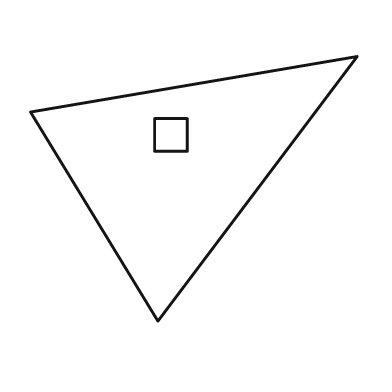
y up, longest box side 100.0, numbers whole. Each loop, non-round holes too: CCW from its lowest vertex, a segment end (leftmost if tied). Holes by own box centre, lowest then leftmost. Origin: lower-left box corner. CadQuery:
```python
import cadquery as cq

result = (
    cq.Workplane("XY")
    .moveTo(39.0, 0.0)
    .lineTo(100.0, 81.0)
    .lineTo(0.0, 64.0)
    .close()
    .moveTo(38.0, 52.0)
    .lineTo(48.0, 52.0)
    .lineTo(48.0, 62.0)
    .lineTo(38.0, 62.0)
    .close()
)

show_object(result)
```